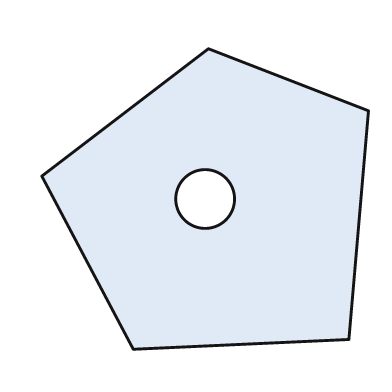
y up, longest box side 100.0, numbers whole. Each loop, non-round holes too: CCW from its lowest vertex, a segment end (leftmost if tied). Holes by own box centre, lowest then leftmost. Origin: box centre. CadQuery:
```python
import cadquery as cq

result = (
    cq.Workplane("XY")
    .moveTo(-22.0, -46.0)
    .lineTo(44.0, -43.0)
    .lineTo(50.0, 27.0)
    .lineTo(1.0, 46.0)
    .lineTo(-50.0, 7.0)
    .close()
    .moveTo(0.0, 0.0)
    .circle(9.0)
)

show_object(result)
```